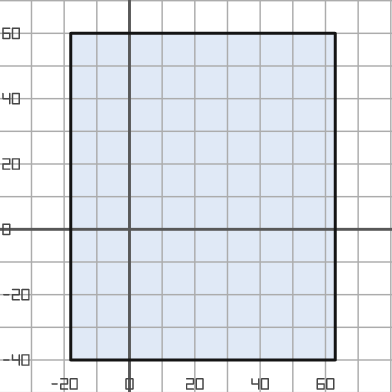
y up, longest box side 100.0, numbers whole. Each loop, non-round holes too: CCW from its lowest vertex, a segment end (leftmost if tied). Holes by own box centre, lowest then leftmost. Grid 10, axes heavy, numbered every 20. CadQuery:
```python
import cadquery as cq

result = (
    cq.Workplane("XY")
    .moveTo(-18.0, -40.0)
    .lineTo(63.0, -40.0)
    .lineTo(63.0, 60.0)
    .lineTo(-18.0, 60.0)
    .close()
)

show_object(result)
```